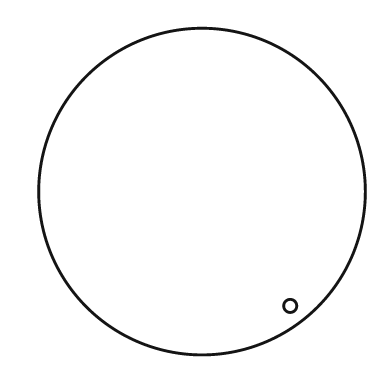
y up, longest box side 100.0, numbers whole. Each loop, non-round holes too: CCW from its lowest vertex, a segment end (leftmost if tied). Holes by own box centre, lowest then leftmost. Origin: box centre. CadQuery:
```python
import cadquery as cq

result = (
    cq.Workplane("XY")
    .moveTo(0.0, 0.0)
    .circle(50.0)
    .moveTo(27.0, -35.0)
    .circle(2.0)
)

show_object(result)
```